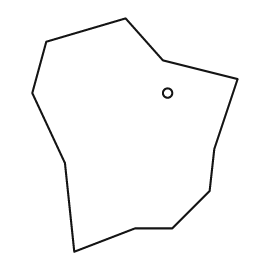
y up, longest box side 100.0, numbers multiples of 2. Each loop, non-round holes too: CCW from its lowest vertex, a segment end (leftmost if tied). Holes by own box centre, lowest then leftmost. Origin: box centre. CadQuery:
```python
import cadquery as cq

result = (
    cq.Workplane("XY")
    .moveTo(-26.0, -50.0)
    .lineTo(0.0, -40.0)
    .lineTo(16.0, -40.0)
    .lineTo(32.0, -24.0)
    .lineTo(34.0, -6.0)
    .lineTo(44.0, 24.0)
    .lineTo(12.0, 32.0)
    .lineTo(-4.0, 50.0)
    .lineTo(-38.0, 40.0)
    .lineTo(-44.0, 18.0)
    .lineTo(-30.0, -12.0)
    .close()
    .moveTo(14.0, 18.0)
    .circle(2.0)
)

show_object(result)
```